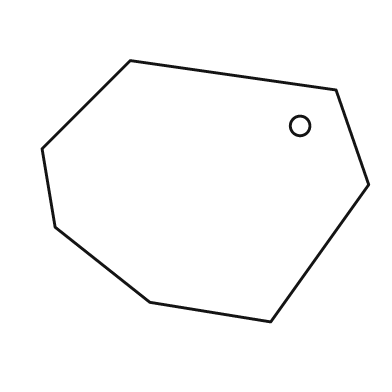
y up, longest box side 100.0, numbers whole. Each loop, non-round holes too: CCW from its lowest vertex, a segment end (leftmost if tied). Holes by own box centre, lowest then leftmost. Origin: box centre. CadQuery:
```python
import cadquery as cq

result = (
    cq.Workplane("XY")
    .moveTo(20.0, -40.0)
    .lineTo(50.0, 2.0)
    .lineTo(40.0, 31.0)
    .lineTo(-23.0, 40.0)
    .lineTo(-50.0, 13.0)
    .lineTo(-46.0, -11.0)
    .lineTo(-17.0, -34.0)
    .close()
    .moveTo(29.0, 20.0)
    .circle(3.0)
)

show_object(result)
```